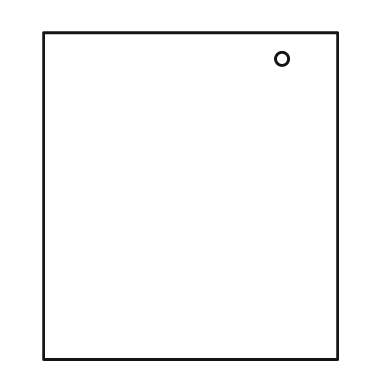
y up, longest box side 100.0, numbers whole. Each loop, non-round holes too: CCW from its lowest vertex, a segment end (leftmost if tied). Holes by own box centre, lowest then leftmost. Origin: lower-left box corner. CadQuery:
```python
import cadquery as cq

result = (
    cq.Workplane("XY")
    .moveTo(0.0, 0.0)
    .lineTo(90.0, 0.0)
    .lineTo(90.0, 100.0)
    .lineTo(0.0, 100.0)
    .close()
    .moveTo(73.0, 92.0)
    .circle(2.0)
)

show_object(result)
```